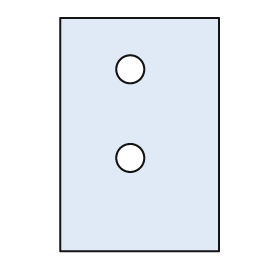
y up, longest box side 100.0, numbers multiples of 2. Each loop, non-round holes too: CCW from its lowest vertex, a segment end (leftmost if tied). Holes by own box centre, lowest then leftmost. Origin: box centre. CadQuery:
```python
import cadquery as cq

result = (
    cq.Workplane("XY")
    .moveTo(-34.0, -50.0)
    .lineTo(34.0, -50.0)
    .lineTo(34.0, 50.0)
    .lineTo(-34.0, 50.0)
    .close()
    .moveTo(-4.0, -10.0)
    .circle(6.0)
    .moveTo(-4.0, 28.0)
    .circle(6.0)
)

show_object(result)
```